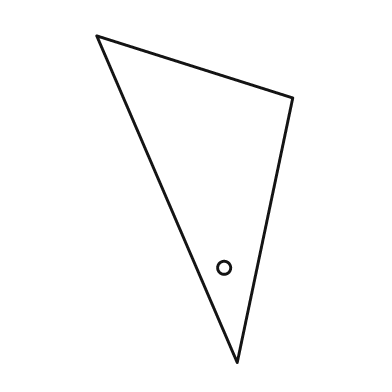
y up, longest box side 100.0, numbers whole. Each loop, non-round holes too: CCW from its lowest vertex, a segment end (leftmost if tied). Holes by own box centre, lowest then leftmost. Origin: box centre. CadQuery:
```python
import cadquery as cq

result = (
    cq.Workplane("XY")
    .moveTo(13.0, -50.0)
    .lineTo(30.0, 31.0)
    .lineTo(-30.0, 50.0)
    .close()
    .moveTo(9.0, -21.0)
    .circle(2.0)
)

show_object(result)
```